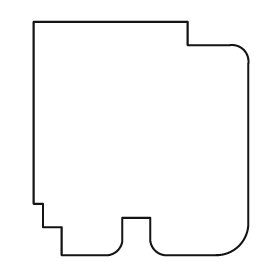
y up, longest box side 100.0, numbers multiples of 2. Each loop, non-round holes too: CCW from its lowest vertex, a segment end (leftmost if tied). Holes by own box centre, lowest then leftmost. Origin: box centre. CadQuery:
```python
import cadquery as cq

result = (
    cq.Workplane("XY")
    .moveTo(-34.0, -50.0)
    .lineTo(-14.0, -50.0)
    .threePointArc((-10.0, -48.0), (-8.0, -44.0))
    .lineTo(-8.0, -34.0)
    .lineTo(4.0, -34.0)
    .lineTo(4.0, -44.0)
    .threePointArc((6.0, -48.0), (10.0, -50.0))
    .lineTo(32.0, -50.0)
    .threePointArc((42.0, -46.0), (46.0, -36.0))
    .lineTo(46.0, 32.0)
    .threePointArc((44.0, 38.0), (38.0, 40.0))
    .lineTo(20.0, 40.0)
    .lineTo(20.0, 50.0)
    .lineTo(-46.0, 50.0)
    .lineTo(-46.0, -28.0)
    .lineTo(-42.0, -28.0)
    .lineTo(-42.0, -38.0)
    .lineTo(-34.0, -38.0)
    .close()
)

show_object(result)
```